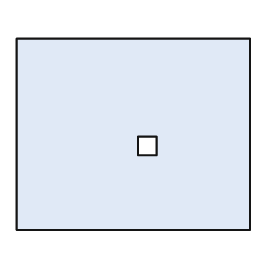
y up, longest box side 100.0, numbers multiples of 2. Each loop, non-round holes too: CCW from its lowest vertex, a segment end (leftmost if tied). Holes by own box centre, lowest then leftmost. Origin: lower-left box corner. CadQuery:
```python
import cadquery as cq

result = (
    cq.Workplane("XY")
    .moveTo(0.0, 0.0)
    .lineTo(100.0, 0.0)
    .lineTo(100.0, 82.0)
    .lineTo(0.0, 82.0)
    .close()
    .moveTo(52.0, 32.0)
    .lineTo(60.0, 32.0)
    .lineTo(60.0, 40.0)
    .lineTo(52.0, 40.0)
    .close()
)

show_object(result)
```